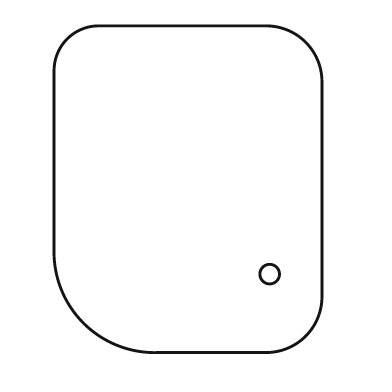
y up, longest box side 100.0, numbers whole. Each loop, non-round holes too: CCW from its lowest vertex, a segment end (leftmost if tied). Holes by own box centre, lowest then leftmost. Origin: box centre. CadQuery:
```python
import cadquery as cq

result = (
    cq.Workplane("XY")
    .moveTo(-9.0, -50.0)
    .lineTo(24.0, -50.0)
    .threePointArc((36.0, -45.0), (41.0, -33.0))
    .lineTo(41.0, 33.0)
    .threePointArc((36.0, 45.0), (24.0, 50.0))
    .lineTo(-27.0, 50.0)
    .threePointArc((-37.0, 46.0), (-41.0, 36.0))
    .lineTo(-41.0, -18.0)
    .threePointArc((-32.0, -41.0), (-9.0, -50.0))
    .close()
    .moveTo(25.0, -26.0)
    .circle(3.0)
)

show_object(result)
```